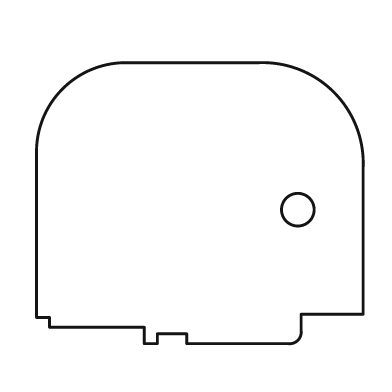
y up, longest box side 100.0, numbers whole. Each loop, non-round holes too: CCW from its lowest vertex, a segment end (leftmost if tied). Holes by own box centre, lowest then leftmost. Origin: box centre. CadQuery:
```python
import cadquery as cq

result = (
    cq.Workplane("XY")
    .moveTo(-17.0, -43.0)
    .lineTo(-13.0, -43.0)
    .lineTo(-13.0, -40.0)
    .lineTo(-4.0, -40.0)
    .lineTo(-4.0, -43.0)
    .lineTo(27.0, -43.0)
    .threePointArc((30.0, -42.0), (31.0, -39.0))
    .lineTo(31.0, -34.0)
    .lineTo(50.0, -34.0)
    .lineTo(50.0, 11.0)
    .threePointArc((41.0, 34.0), (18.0, 43.0))
    .lineTo(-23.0, 43.0)
    .threePointArc((-42.0, 35.0), (-50.0, 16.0))
    .lineTo(-50.0, -35.0)
    .lineTo(-46.0, -35.0)
    .lineTo(-46.0, -38.0)
    .lineTo(-17.0, -38.0)
    .close()
    .moveTo(30.0, -2.0)
    .circle(5.0)
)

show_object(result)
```